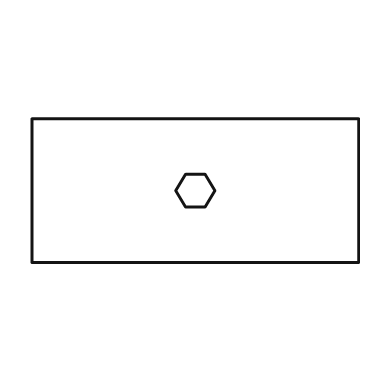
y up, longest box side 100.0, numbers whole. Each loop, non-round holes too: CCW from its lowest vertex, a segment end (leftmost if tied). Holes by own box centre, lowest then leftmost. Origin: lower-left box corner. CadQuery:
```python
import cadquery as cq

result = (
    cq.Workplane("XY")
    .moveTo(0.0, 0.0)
    .lineTo(100.0, 0.0)
    .lineTo(100.0, 44.0)
    .lineTo(0.0, 44.0)
    .close()
    .moveTo(47.0, 17.0)
    .lineTo(53.0, 17.0)
    .lineTo(56.0, 22.0)
    .lineTo(53.0, 27.0)
    .lineTo(47.0, 27.0)
    .lineTo(44.0, 22.0)
    .close()
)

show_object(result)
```